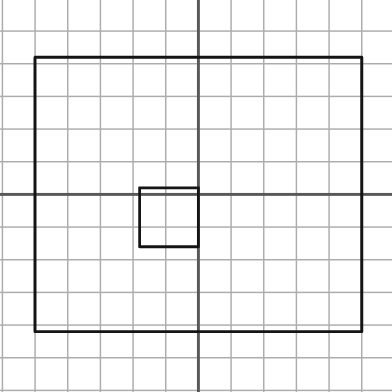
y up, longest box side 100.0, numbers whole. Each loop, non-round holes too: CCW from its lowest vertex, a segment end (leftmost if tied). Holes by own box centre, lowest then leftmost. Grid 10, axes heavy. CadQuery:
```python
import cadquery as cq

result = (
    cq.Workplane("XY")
    .moveTo(-50.0, -42.0)
    .lineTo(50.0, -42.0)
    .lineTo(50.0, 42.0)
    .lineTo(-50.0, 42.0)
    .close()
    .moveTo(-18.0, -16.0)
    .lineTo(0.0, -16.0)
    .lineTo(0.0, 2.0)
    .lineTo(-18.0, 2.0)
    .close()
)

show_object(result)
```